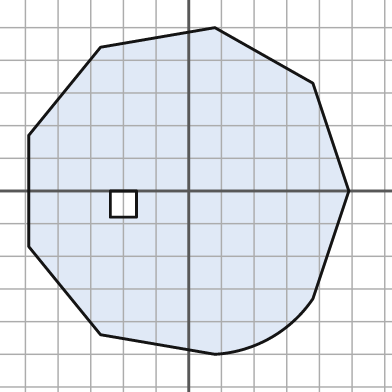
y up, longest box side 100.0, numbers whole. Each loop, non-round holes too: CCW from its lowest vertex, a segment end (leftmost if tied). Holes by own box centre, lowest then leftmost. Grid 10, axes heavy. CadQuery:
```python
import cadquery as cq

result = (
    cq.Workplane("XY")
    .moveTo(8.0, -50.0)
    .threePointArc((25.0, -45.0), (38.0, -33.0))
    .lineTo(49.0, 0.0)
    .lineTo(38.0, 33.0)
    .lineTo(8.0, 50.0)
    .lineTo(-27.0, 44.0)
    .lineTo(-49.0, 17.0)
    .lineTo(-49.0, -17.0)
    .lineTo(-27.0, -44.0)
    .close()
    .moveTo(-24.0, -8.0)
    .lineTo(-16.0, -8.0)
    .lineTo(-16.0, 0.0)
    .lineTo(-24.0, 0.0)
    .close()
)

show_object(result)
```